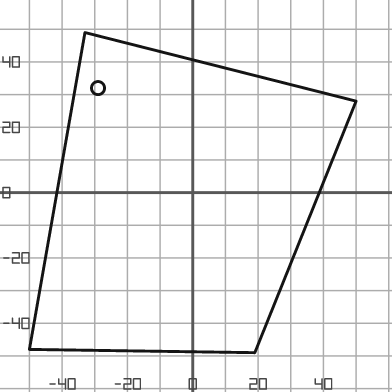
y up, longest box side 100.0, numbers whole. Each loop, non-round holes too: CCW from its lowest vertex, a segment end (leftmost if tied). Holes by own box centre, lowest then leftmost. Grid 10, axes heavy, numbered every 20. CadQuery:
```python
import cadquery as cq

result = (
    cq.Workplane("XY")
    .moveTo(19.0, -49.0)
    .lineTo(50.0, 28.0)
    .lineTo(-33.0, 49.0)
    .lineTo(-50.0, -48.0)
    .close()
    .moveTo(-29.0, 32.0)
    .circle(2.0)
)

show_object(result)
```